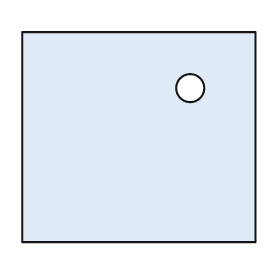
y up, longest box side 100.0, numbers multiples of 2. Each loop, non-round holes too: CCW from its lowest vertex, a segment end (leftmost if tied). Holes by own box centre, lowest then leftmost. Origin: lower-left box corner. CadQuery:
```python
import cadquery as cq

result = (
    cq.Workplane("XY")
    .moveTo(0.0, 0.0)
    .lineTo(100.0, 0.0)
    .lineTo(100.0, 90.0)
    .lineTo(0.0, 90.0)
    .close()
    .moveTo(72.0, 66.0)
    .circle(6.0)
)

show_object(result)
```